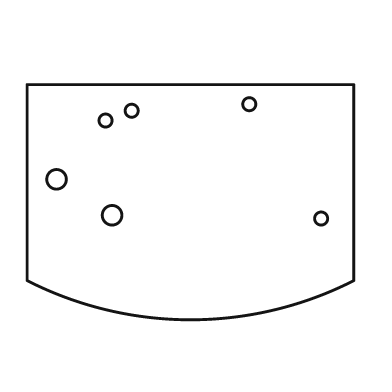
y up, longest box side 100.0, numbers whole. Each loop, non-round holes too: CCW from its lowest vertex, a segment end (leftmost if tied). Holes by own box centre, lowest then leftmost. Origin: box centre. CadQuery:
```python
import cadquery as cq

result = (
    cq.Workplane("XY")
    .moveTo(-50.0, -24.0)
    .threePointArc((0.0, -36.0), (50.0, -24.0))
    .lineTo(50.0, 36.0)
    .lineTo(-50.0, 36.0)
    .close()
    .moveTo(40.0, -5.0)
    .circle(2.0)
    .moveTo(-24.0, -4.0)
    .circle(3.0)
    .moveTo(-41.0, 7.0)
    .circle(3.0)
    .moveTo(-26.0, 25.0)
    .circle(2.0)
    .moveTo(-18.0, 28.0)
    .circle(2.0)
    .moveTo(18.0, 30.0)
    .circle(2.0)
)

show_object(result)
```